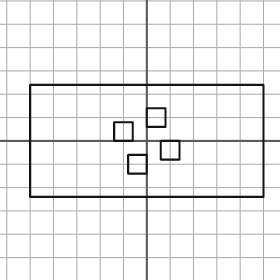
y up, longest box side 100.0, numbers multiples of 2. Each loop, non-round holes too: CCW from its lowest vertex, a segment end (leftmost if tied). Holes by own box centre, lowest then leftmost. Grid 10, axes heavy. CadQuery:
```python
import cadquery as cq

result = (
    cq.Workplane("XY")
    .moveTo(-50.0, -24.0)
    .lineTo(50.0, -24.0)
    .lineTo(50.0, 24.0)
    .lineTo(-50.0, 24.0)
    .close()
    .moveTo(-8.0, -14.0)
    .lineTo(0.0, -14.0)
    .lineTo(0.0, -6.0)
    .lineTo(-8.0, -6.0)
    .close()
    .moveTo(6.0, -8.0)
    .lineTo(14.0, -8.0)
    .lineTo(14.0, 0.0)
    .lineTo(6.0, 0.0)
    .close()
    .moveTo(-14.0, 0.0)
    .lineTo(-6.0, 0.0)
    .lineTo(-6.0, 8.0)
    .lineTo(-14.0, 8.0)
    .close()
    .moveTo(0.0, 6.0)
    .lineTo(8.0, 6.0)
    .lineTo(8.0, 14.0)
    .lineTo(0.0, 14.0)
    .close()
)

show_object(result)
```